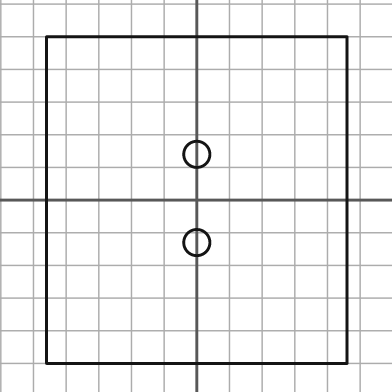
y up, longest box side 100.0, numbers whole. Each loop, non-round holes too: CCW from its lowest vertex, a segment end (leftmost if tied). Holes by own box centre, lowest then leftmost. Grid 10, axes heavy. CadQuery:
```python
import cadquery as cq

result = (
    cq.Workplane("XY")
    .moveTo(-46.0, -50.0)
    .lineTo(46.0, -50.0)
    .lineTo(46.0, 50.0)
    .lineTo(-46.0, 50.0)
    .close()
    .moveTo(0.0, -13.0)
    .circle(4.0)
    .moveTo(0.0, 14.0)
    .circle(4.0)
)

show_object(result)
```